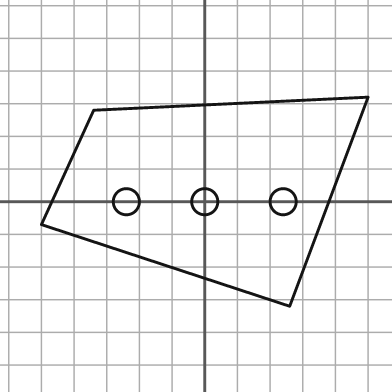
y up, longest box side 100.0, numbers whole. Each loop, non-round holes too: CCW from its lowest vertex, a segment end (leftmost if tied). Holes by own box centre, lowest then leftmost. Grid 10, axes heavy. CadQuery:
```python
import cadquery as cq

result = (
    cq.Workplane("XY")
    .moveTo(26.0, -32.0)
    .lineTo(50.0, 32.0)
    .lineTo(-34.0, 28.0)
    .lineTo(-50.0, -7.0)
    .close()
    .moveTo(-24.0, 0.0)
    .circle(4.0)
    .moveTo(0.0, 0.0)
    .circle(4.0)
    .moveTo(24.0, 0.0)
    .circle(4.0)
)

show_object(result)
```